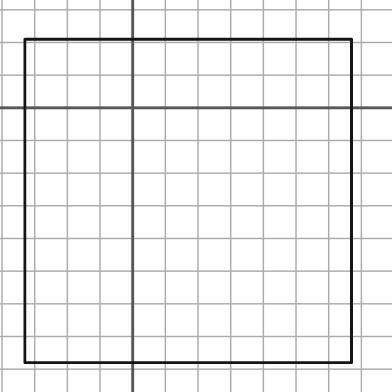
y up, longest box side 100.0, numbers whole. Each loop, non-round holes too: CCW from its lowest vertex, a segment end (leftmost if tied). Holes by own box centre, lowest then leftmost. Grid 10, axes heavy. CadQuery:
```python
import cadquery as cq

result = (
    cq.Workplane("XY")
    .moveTo(-33.0, -78.0)
    .lineTo(67.0, -78.0)
    .lineTo(67.0, 21.0)
    .lineTo(-33.0, 21.0)
    .close()
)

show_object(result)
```